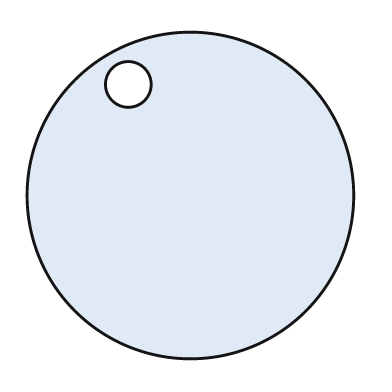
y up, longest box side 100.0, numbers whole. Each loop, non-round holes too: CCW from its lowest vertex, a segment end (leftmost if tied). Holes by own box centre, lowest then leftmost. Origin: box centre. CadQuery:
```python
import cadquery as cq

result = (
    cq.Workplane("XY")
    .moveTo(0.0, 0.0)
    .circle(50.0)
    .moveTo(-19.0, 34.0)
    .circle(7.0)
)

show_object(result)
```